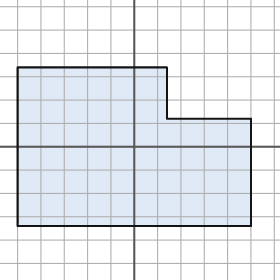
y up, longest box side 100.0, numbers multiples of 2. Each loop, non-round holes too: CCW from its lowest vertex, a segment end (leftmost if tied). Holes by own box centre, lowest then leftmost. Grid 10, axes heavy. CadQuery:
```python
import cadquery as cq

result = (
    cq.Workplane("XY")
    .moveTo(-50.0, -34.0)
    .lineTo(50.0, -34.0)
    .lineTo(50.0, 12.0)
    .lineTo(14.0, 12.0)
    .lineTo(14.0, 34.0)
    .lineTo(-50.0, 34.0)
    .close()
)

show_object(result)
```